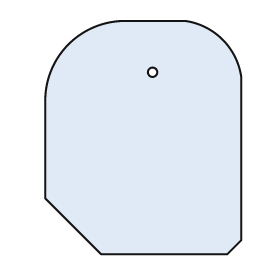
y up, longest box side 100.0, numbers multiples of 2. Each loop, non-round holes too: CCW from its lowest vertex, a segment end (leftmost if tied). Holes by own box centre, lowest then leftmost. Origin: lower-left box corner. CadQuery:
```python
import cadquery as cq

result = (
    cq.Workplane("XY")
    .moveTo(24.0, 0.0)
    .lineTo(78.0, 0.0)
    .lineTo(84.0, 6.0)
    .lineTo(84.0, 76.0)
    .threePointArc((76.0, 92.0), (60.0, 100.0))
    .lineTo(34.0, 100.0)
    .threePointArc((10.0, 90.0), (0.0, 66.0))
    .lineTo(0.0, 24.0)
    .close()
    .moveTo(46.0, 78.0)
    .circle(2.0)
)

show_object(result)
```